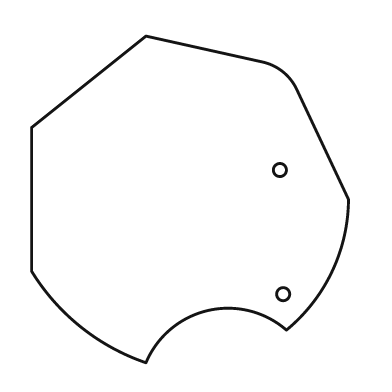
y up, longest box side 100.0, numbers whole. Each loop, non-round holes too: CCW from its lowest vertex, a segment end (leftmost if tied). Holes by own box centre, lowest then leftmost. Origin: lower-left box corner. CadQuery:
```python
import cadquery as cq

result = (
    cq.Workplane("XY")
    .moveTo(35.0, 0.0)
    .threePointArc((54.0, 16.0), (78.0, 10.0))
    .threePointArc((92.0, 28.0), (97.0, 50.0))
    .lineTo(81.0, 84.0)
    .threePointArc((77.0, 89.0), (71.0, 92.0))
    .lineTo(35.0, 100.0)
    .lineTo(0.0, 72.0)
    .lineTo(0.0, 28.0)
    .threePointArc((15.0, 11.0), (35.0, 0.0))
    .close()
    .moveTo(77.0, 21.0)
    .circle(2.0)
    .moveTo(76.0, 59.0)
    .circle(2.0)
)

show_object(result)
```